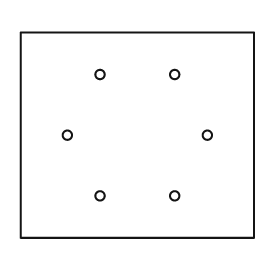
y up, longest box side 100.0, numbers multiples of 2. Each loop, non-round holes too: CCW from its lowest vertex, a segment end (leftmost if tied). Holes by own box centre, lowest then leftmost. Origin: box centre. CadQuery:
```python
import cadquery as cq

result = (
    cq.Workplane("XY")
    .moveTo(-50.0, -44.0)
    .lineTo(50.0, -44.0)
    .lineTo(50.0, 44.0)
    .lineTo(-50.0, 44.0)
    .close()
    .moveTo(-16.0, -26.0)
    .circle(2.0)
    .moveTo(16.0, -26.0)
    .circle(2.0)
    .moveTo(-30.0, 0.0)
    .circle(2.0)
    .moveTo(30.0, 0.0)
    .circle(2.0)
    .moveTo(-16.0, 26.0)
    .circle(2.0)
    .moveTo(16.0, 26.0)
    .circle(2.0)
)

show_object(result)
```